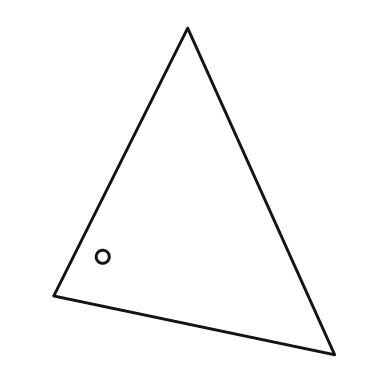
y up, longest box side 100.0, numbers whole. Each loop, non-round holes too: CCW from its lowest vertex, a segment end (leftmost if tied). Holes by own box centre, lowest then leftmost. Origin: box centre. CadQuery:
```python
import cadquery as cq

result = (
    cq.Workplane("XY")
    .moveTo(43.0, -50.0)
    .lineTo(-2.0, 50.0)
    .lineTo(-43.0, -32.0)
    .close()
    .moveTo(-28.0, -20.0)
    .circle(2.0)
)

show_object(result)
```